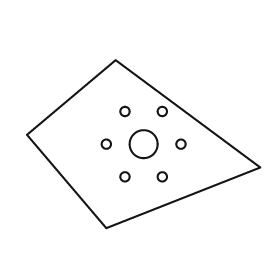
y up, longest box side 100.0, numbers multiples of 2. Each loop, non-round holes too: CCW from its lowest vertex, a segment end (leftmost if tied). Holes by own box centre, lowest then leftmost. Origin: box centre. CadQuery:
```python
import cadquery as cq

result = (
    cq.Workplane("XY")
    .moveTo(-16.0, -36.0)
    .lineTo(50.0, -10.0)
    .lineTo(-12.0, 36.0)
    .lineTo(-50.0, 4.0)
    .close()
    .moveTo(-8.0, -14.0)
    .circle(2.0)
    .moveTo(8.0, -14.0)
    .circle(2.0)
    .moveTo(-16.0, 0.0)
    .circle(2.0)
    .moveTo(0.0, 0.0)
    .circle(6.0)
    .moveTo(16.0, 0.0)
    .circle(2.0)
    .moveTo(-8.0, 14.0)
    .circle(2.0)
    .moveTo(8.0, 14.0)
    .circle(2.0)
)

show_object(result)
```